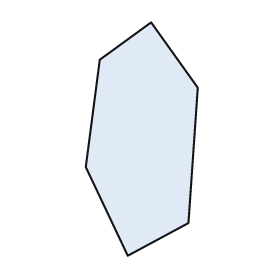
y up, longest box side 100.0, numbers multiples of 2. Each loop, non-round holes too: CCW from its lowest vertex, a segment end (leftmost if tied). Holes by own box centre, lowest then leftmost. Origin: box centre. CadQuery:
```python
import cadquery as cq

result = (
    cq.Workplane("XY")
    .moveTo(-6.0, -50.0)
    .lineTo(20.0, -36.0)
    .lineTo(24.0, 22.0)
    .lineTo(4.0, 50.0)
    .lineTo(-18.0, 34.0)
    .lineTo(-24.0, -12.0)
    .close()
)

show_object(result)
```